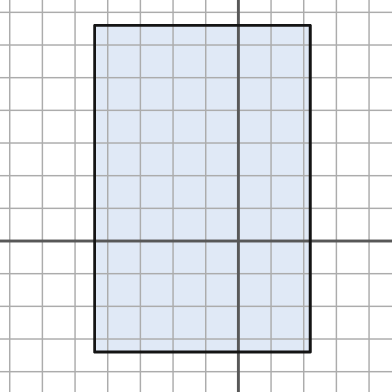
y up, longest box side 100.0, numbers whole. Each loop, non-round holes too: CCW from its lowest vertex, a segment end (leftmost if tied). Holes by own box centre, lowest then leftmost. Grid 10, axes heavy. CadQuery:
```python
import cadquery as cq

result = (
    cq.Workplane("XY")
    .moveTo(-44.0, -34.0)
    .lineTo(22.0, -34.0)
    .lineTo(22.0, 66.0)
    .lineTo(-44.0, 66.0)
    .close()
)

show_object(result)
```